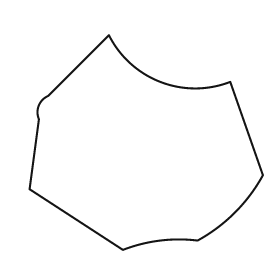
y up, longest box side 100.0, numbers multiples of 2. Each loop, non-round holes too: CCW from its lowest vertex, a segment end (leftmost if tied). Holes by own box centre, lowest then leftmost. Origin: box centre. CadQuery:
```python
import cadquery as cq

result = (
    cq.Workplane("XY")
    .moveTo(-10.0, -46.0)
    .threePointArc((6.0, -42.0), (22.0, -42.0))
    .threePointArc((38.0, -30.0), (50.0, -14.0))
    .lineTo(36.0, 26.0)
    .threePointArc((6.0, 26.0), (-16.0, 46.0))
    .lineTo(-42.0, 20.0)
    .threePointArc((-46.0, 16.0), (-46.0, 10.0))
    .lineTo(-50.0, -20.0)
    .close()
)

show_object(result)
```